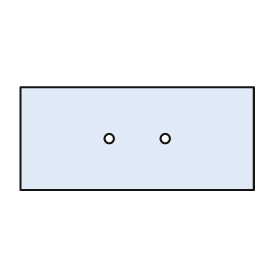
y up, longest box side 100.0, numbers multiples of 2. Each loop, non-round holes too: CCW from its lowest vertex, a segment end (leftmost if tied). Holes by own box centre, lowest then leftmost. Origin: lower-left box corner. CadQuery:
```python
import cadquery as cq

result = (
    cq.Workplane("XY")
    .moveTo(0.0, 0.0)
    .lineTo(100.0, 0.0)
    .lineTo(100.0, 44.0)
    .lineTo(0.0, 44.0)
    .close()
    .moveTo(38.0, 22.0)
    .circle(2.0)
    .moveTo(62.0, 22.0)
    .circle(2.0)
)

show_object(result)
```